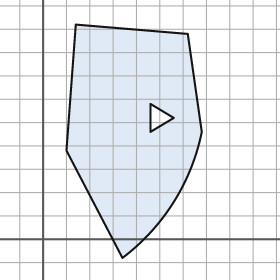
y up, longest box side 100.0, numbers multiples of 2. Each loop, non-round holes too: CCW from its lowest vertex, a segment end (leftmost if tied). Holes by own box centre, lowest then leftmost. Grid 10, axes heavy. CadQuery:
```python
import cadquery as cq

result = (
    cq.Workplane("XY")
    .moveTo(34.0, -8.0)
    .threePointArc((56.0, 16.0), (68.0, 46.0))
    .lineTo(62.0, 88.0)
    .lineTo(14.0, 92.0)
    .lineTo(10.0, 38.0)
    .close()
    .moveTo(46.0, 46.0)
    .lineTo(56.0, 52.0)
    .lineTo(46.0, 58.0)
    .close()
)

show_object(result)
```